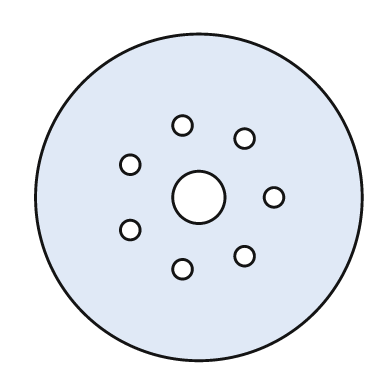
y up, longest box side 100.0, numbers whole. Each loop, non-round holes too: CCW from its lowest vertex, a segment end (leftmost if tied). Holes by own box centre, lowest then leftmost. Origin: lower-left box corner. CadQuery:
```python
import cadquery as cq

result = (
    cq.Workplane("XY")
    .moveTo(50.0, 50.0)
    .circle(50.0)
    .moveTo(45.0, 28.0)
    .circle(3.0)
    .moveTo(64.0, 32.0)
    .circle(3.0)
    .moveTo(29.0, 40.0)
    .circle(3.0)
    .moveTo(50.0, 50.0)
    .circle(8.0)
    .moveTo(73.0, 50.0)
    .circle(3.0)
    .moveTo(29.0, 60.0)
    .circle(3.0)
    .moveTo(64.0, 68.0)
    .circle(3.0)
    .moveTo(45.0, 72.0)
    .circle(3.0)
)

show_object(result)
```